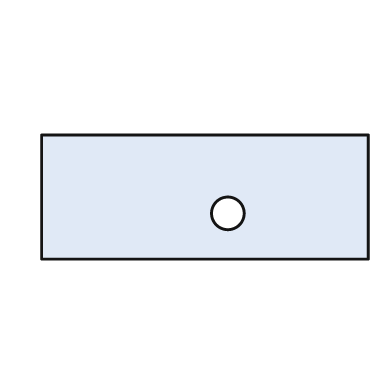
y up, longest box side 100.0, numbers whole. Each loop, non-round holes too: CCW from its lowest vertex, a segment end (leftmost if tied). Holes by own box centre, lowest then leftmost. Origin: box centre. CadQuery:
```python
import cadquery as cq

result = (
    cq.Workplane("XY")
    .moveTo(-50.0, -19.0)
    .lineTo(50.0, -19.0)
    .lineTo(50.0, 19.0)
    .lineTo(-50.0, 19.0)
    .close()
    .moveTo(7.0, -5.0)
    .circle(5.0)
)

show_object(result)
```